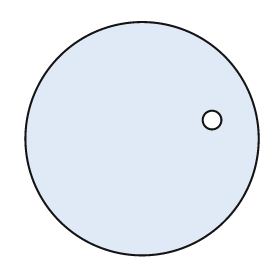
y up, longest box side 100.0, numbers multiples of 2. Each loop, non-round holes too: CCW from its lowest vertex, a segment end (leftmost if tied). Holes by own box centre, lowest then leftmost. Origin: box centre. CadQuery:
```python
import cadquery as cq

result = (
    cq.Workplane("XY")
    .moveTo(0.0, 0.0)
    .circle(50.0)
    .moveTo(30.0, 8.0)
    .circle(4.0)
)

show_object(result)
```